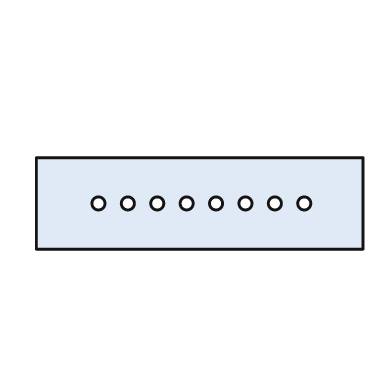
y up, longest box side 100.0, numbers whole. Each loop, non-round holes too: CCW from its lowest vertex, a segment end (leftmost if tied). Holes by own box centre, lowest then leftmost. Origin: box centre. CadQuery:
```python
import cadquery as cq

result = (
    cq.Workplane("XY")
    .moveTo(-50.0, -14.0)
    .lineTo(50.0, -14.0)
    .lineTo(50.0, 14.0)
    .lineTo(-50.0, 14.0)
    .close()
    .moveTo(-31.0, 0.0)
    .circle(2.0)
    .moveTo(-22.0, 0.0)
    .circle(2.0)
    .moveTo(-13.0, 0.0)
    .circle(2.0)
    .moveTo(-4.0, 0.0)
    .circle(2.0)
    .moveTo(5.0, 0.0)
    .circle(2.0)
    .moveTo(14.0, 0.0)
    .circle(2.0)
    .moveTo(23.0, 0.0)
    .circle(2.0)
    .moveTo(32.0, 0.0)
    .circle(2.0)
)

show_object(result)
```